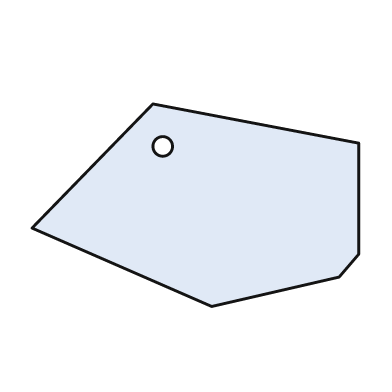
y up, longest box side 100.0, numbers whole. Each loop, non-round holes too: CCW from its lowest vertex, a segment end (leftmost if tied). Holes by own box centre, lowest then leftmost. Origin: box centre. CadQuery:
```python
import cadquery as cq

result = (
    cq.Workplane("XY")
    .moveTo(5.0, -31.0)
    .lineTo(44.0, -22.0)
    .lineTo(50.0, -15.0)
    .lineTo(50.0, 19.0)
    .lineTo(-13.0, 31.0)
    .lineTo(-50.0, -7.0)
    .close()
    .moveTo(-10.0, 18.0)
    .circle(3.0)
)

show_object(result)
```